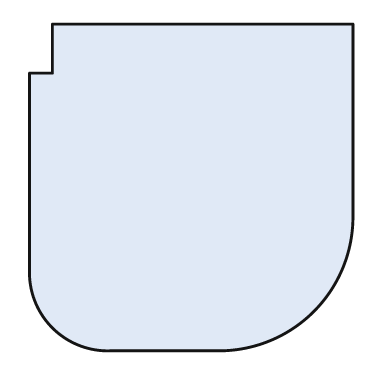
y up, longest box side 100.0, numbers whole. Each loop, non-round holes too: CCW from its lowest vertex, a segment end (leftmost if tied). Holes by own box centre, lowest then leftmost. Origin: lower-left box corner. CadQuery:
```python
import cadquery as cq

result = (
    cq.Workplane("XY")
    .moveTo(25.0, 0.0)
    .lineTo(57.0, 0.0)
    .threePointArc((87.0, 12.0), (99.0, 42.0))
    .lineTo(99.0, 100.0)
    .lineTo(7.0, 100.0)
    .lineTo(7.0, 85.0)
    .lineTo(0.0, 85.0)
    .lineTo(0.0, 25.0)
    .threePointArc((7.0, 7.0), (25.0, 0.0))
    .close()
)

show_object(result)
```